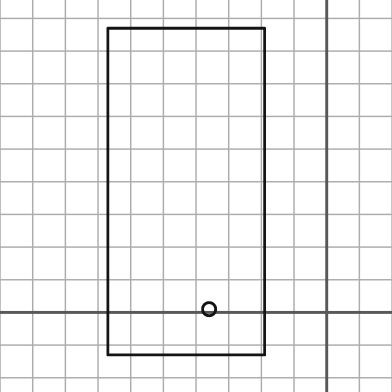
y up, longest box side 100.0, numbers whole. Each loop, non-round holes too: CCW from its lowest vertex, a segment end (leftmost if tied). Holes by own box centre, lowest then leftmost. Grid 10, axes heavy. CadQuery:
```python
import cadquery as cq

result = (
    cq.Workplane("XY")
    .moveTo(-67.0, -13.0)
    .lineTo(-19.0, -13.0)
    .lineTo(-19.0, 87.0)
    .lineTo(-67.0, 87.0)
    .close()
    .moveTo(-36.0, 1.0)
    .circle(2.0)
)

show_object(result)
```